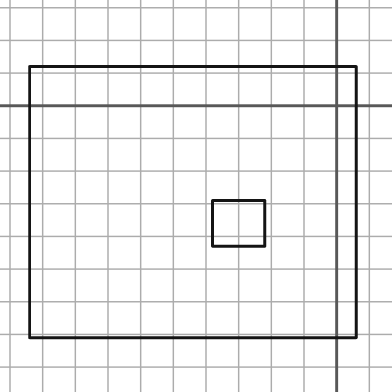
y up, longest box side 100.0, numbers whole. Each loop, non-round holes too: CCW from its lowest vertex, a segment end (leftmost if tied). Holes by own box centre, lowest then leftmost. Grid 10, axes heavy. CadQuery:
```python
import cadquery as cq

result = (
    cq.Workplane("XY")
    .moveTo(-94.0, -71.0)
    .lineTo(6.0, -71.0)
    .lineTo(6.0, 12.0)
    .lineTo(-94.0, 12.0)
    .close()
    .moveTo(-38.0, -43.0)
    .lineTo(-22.0, -43.0)
    .lineTo(-22.0, -29.0)
    .lineTo(-38.0, -29.0)
    .close()
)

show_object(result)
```